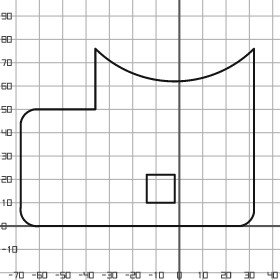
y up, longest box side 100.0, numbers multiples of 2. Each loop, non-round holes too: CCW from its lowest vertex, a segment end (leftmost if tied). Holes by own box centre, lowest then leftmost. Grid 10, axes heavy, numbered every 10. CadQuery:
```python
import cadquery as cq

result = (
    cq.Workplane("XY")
    .moveTo(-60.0, 0.0)
    .lineTo(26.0, 0.0)
    .threePointArc((30.0, 2.0), (32.0, 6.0))
    .lineTo(32.0, 76.0)
    .threePointArc((-2.0, 62.0), (-36.0, 76.0))
    .lineTo(-36.0, 50.0)
    .lineTo(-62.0, 50.0)
    .threePointArc((-66.0, 48.0), (-68.0, 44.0))
    .lineTo(-68.0, 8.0)
    .threePointArc((-66.0, 2.0), (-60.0, 0.0))
    .close()
    .moveTo(-14.0, 10.0)
    .lineTo(-2.0, 10.0)
    .lineTo(-2.0, 22.0)
    .lineTo(-14.0, 22.0)
    .close()
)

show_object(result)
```